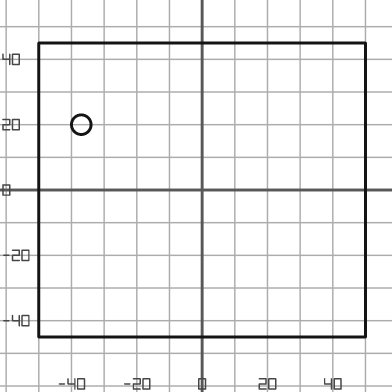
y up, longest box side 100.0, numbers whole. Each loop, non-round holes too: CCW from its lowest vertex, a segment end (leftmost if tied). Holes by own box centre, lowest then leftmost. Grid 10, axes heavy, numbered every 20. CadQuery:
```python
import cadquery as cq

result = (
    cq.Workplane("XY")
    .moveTo(-50.0, -45.0)
    .lineTo(50.0, -45.0)
    .lineTo(50.0, 45.0)
    .lineTo(-50.0, 45.0)
    .close()
    .moveTo(-37.0, 20.0)
    .circle(3.0)
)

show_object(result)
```